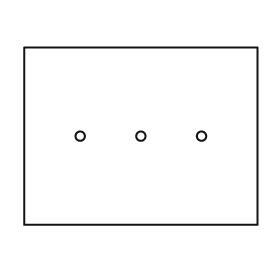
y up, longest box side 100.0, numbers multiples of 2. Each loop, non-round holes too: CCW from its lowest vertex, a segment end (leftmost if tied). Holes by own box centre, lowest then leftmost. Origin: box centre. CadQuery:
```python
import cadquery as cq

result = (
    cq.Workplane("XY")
    .moveTo(-50.0, -38.0)
    .lineTo(50.0, -38.0)
    .lineTo(50.0, 38.0)
    .lineTo(-50.0, 38.0)
    .close()
    .moveTo(-26.0, 0.0)
    .circle(2.0)
    .moveTo(0.0, 0.0)
    .circle(2.0)
    .moveTo(26.0, 0.0)
    .circle(2.0)
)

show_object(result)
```